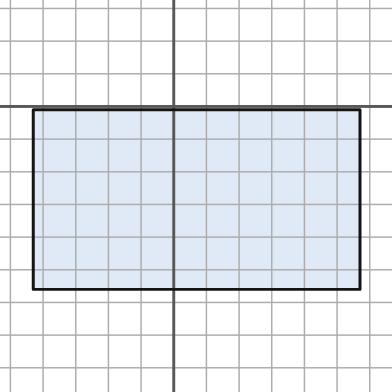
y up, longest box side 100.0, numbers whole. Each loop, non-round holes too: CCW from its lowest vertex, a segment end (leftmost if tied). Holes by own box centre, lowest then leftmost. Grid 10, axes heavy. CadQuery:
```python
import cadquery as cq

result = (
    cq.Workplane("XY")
    .moveTo(-43.0, -56.0)
    .lineTo(57.0, -56.0)
    .lineTo(57.0, -1.0)
    .lineTo(-43.0, -1.0)
    .close()
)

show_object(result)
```